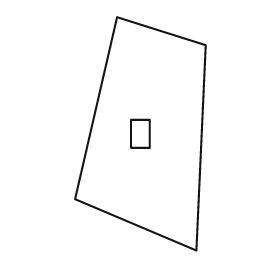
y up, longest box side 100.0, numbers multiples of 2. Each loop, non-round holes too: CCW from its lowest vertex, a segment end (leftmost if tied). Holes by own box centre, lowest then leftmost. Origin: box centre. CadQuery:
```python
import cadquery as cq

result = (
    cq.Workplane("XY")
    .moveTo(24.0, -50.0)
    .lineTo(28.0, 38.0)
    .lineTo(-10.0, 50.0)
    .lineTo(-28.0, -28.0)
    .close()
    .moveTo(-4.0, -6.0)
    .lineTo(4.0, -6.0)
    .lineTo(4.0, 6.0)
    .lineTo(-4.0, 6.0)
    .close()
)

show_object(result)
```